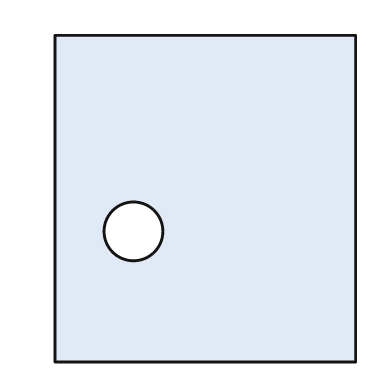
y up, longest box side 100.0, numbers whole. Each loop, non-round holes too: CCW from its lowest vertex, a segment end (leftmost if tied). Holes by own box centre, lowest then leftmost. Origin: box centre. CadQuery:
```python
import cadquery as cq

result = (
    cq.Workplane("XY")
    .moveTo(-46.0, -50.0)
    .lineTo(46.0, -50.0)
    .lineTo(46.0, 50.0)
    .lineTo(-46.0, 50.0)
    .close()
    .moveTo(-22.0, -10.0)
    .circle(9.0)
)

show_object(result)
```